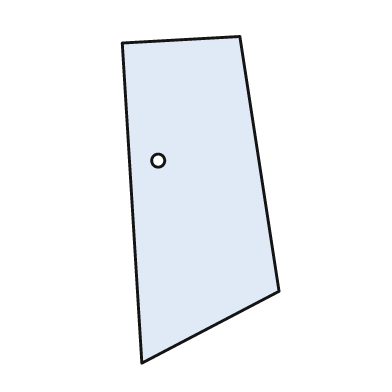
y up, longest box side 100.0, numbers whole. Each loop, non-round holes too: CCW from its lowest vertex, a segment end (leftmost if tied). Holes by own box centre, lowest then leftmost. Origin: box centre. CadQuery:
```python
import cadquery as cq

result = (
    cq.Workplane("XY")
    .moveTo(-18.0, -50.0)
    .lineTo(24.0, -28.0)
    .lineTo(12.0, 50.0)
    .lineTo(-24.0, 48.0)
    .close()
    .moveTo(-13.0, 12.0)
    .circle(2.0)
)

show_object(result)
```